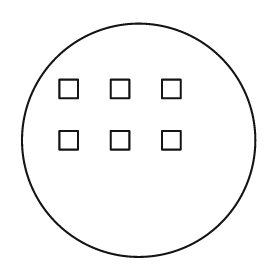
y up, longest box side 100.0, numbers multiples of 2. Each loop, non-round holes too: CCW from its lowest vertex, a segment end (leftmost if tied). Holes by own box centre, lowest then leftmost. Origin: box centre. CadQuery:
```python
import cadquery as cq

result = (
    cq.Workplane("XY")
    .moveTo(0.0, 0.0)
    .circle(50.0)
    .moveTo(-34.0, -4.0)
    .lineTo(-26.0, -4.0)
    .lineTo(-26.0, 4.0)
    .lineTo(-34.0, 4.0)
    .close()
    .moveTo(-12.0, -4.0)
    .lineTo(-4.0, -4.0)
    .lineTo(-4.0, 4.0)
    .lineTo(-12.0, 4.0)
    .close()
    .moveTo(10.0, -4.0)
    .lineTo(18.0, -4.0)
    .lineTo(18.0, 4.0)
    .lineTo(10.0, 4.0)
    .close()
    .moveTo(-34.0, 18.0)
    .lineTo(-26.0, 18.0)
    .lineTo(-26.0, 26.0)
    .lineTo(-34.0, 26.0)
    .close()
    .moveTo(-12.0, 18.0)
    .lineTo(-4.0, 18.0)
    .lineTo(-4.0, 26.0)
    .lineTo(-12.0, 26.0)
    .close()
    .moveTo(10.0, 18.0)
    .lineTo(18.0, 18.0)
    .lineTo(18.0, 26.0)
    .lineTo(10.0, 26.0)
    .close()
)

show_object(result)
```